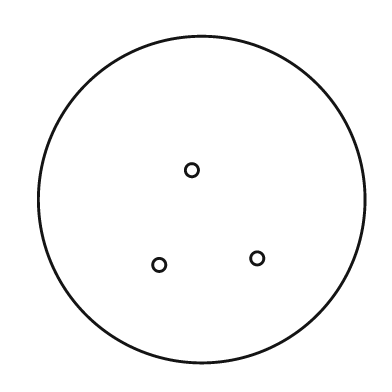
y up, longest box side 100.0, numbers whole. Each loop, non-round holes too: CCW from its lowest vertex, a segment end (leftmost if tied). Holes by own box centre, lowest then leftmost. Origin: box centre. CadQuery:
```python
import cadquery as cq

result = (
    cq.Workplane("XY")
    .moveTo(0.0, 0.0)
    .circle(50.0)
    .moveTo(-13.0, -20.0)
    .circle(2.0)
    .moveTo(17.0, -18.0)
    .circle(2.0)
    .moveTo(-3.0, 9.0)
    .circle(2.0)
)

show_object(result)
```